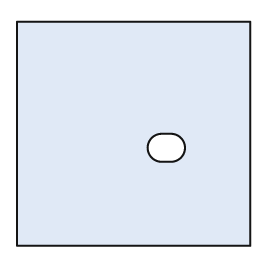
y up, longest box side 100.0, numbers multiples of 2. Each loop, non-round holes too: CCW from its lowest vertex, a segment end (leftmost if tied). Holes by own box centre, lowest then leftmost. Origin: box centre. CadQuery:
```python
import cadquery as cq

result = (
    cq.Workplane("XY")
    .moveTo(-50.0, -48.0)
    .lineTo(50.0, -48.0)
    .lineTo(50.0, 48.0)
    .lineTo(-50.0, 48.0)
    .close()
    .moveTo(12.0, -12.0)
    .lineTo(16.0, -12.0)
    .threePointArc((22.0, -6.0), (16.0, 0.0))
    .lineTo(12.0, 0.0)
    .threePointArc((6.0, -6.0), (12.0, -12.0))
    .close()
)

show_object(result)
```